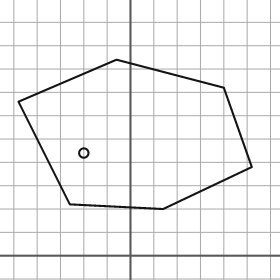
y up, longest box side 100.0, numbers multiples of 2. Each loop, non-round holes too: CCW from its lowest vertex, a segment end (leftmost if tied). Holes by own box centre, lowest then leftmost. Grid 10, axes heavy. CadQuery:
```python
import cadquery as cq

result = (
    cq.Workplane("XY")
    .moveTo(14.0, 20.0)
    .lineTo(52.0, 38.0)
    .lineTo(40.0, 72.0)
    .lineTo(-6.0, 84.0)
    .lineTo(-48.0, 66.0)
    .lineTo(-26.0, 22.0)
    .close()
    .moveTo(-20.0, 44.0)
    .circle(2.0)
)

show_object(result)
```